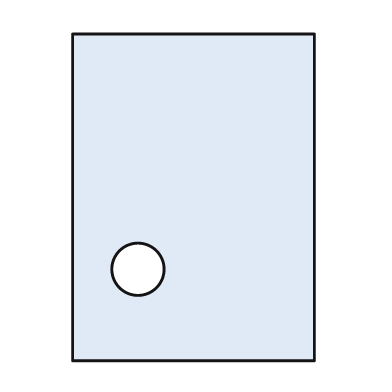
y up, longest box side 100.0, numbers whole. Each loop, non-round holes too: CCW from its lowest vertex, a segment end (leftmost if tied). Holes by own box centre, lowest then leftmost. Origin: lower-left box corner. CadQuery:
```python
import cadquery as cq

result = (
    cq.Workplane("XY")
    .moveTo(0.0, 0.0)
    .lineTo(74.0, 0.0)
    .lineTo(74.0, 100.0)
    .lineTo(0.0, 100.0)
    .close()
    .moveTo(20.0, 28.0)
    .circle(8.0)
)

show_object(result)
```